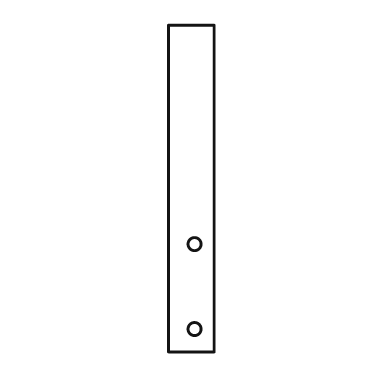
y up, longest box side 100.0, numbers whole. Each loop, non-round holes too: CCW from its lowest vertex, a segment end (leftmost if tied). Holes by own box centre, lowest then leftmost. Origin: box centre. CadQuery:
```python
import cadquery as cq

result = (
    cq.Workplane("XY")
    .moveTo(-7.0, -50.0)
    .lineTo(7.0, -50.0)
    .lineTo(7.0, 50.0)
    .lineTo(-7.0, 50.0)
    .close()
    .moveTo(1.0, -43.0)
    .circle(2.0)
    .moveTo(1.0, -17.0)
    .circle(2.0)
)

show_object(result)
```